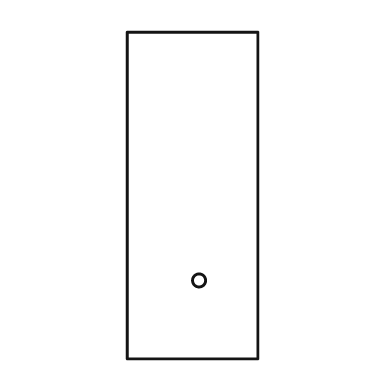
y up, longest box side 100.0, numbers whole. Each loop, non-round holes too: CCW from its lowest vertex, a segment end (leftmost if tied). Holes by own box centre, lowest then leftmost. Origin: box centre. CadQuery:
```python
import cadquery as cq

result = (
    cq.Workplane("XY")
    .moveTo(-20.0, -50.0)
    .lineTo(20.0, -50.0)
    .lineTo(20.0, 50.0)
    .lineTo(-20.0, 50.0)
    .close()
    .moveTo(2.0, -26.0)
    .circle(2.0)
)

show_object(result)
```